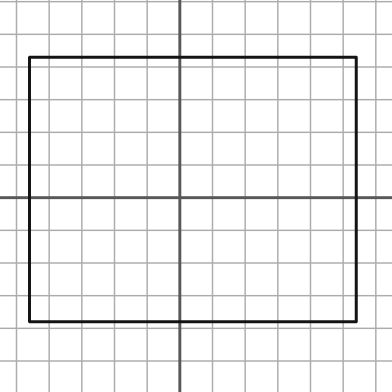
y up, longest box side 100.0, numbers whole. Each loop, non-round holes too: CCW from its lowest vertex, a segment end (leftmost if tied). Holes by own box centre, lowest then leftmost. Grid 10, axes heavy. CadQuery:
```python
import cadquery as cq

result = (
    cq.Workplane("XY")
    .moveTo(-46.0, -38.0)
    .lineTo(54.0, -38.0)
    .lineTo(54.0, 43.0)
    .lineTo(-46.0, 43.0)
    .close()
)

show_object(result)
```